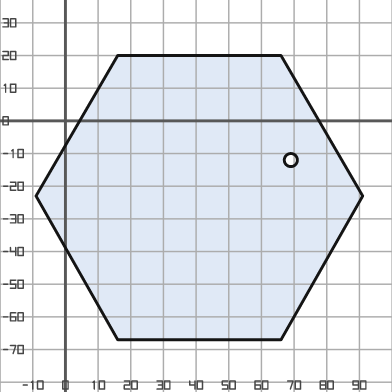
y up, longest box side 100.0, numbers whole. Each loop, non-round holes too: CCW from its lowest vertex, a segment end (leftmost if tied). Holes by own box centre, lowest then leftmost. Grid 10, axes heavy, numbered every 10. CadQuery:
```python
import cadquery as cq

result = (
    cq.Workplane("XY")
    .moveTo(16.0, -67.0)
    .lineTo(66.0, -67.0)
    .lineTo(91.0, -23.0)
    .lineTo(66.0, 20.0)
    .lineTo(16.0, 20.0)
    .lineTo(-9.0, -23.0)
    .close()
    .moveTo(69.0, -12.0)
    .circle(2.0)
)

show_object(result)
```